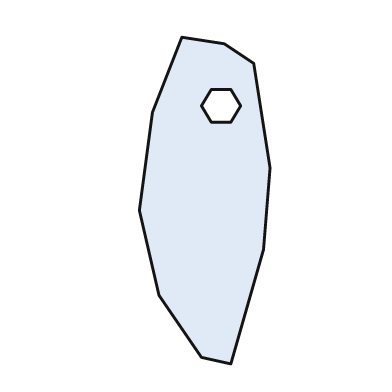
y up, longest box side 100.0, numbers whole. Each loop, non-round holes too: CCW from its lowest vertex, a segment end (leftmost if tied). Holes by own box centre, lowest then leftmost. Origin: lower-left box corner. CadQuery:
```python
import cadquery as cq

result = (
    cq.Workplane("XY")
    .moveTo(28.0, 0.0)
    .lineTo(38.0, 35.0)
    .lineTo(40.0, 60.0)
    .lineTo(35.0, 92.0)
    .lineTo(26.0, 98.0)
    .lineTo(13.0, 100.0)
    .lineTo(4.0, 77.0)
    .lineTo(0.0, 47.0)
    .lineTo(6.0, 21.0)
    .lineTo(19.0, 2.0)
    .close()
    .moveTo(22.0, 74.0)
    .lineTo(28.0, 74.0)
    .lineTo(31.0, 79.0)
    .lineTo(28.0, 84.0)
    .lineTo(22.0, 84.0)
    .lineTo(19.0, 79.0)
    .close()
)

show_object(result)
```